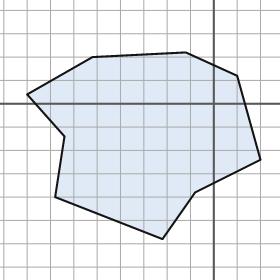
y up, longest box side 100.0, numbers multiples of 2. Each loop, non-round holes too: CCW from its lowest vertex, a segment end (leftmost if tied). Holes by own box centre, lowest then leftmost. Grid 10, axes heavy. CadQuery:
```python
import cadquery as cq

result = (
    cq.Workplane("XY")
    .moveTo(-22.0, -58.0)
    .lineTo(-8.0, -38.0)
    .lineTo(20.0, -24.0)
    .lineTo(10.0, 12.0)
    .lineTo(-12.0, 22.0)
    .lineTo(-52.0, 20.0)
    .lineTo(-80.0, 4.0)
    .lineTo(-64.0, -14.0)
    .lineTo(-68.0, -40.0)
    .close()
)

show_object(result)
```